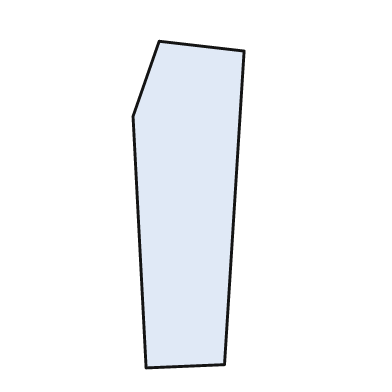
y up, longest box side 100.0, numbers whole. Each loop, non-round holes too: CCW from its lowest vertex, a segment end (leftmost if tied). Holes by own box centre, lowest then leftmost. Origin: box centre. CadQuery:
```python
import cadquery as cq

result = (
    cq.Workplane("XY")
    .moveTo(-13.0, -50.0)
    .lineTo(11.0, -49.0)
    .lineTo(17.0, 47.0)
    .lineTo(-9.0, 50.0)
    .lineTo(-17.0, 27.0)
    .close()
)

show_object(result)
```